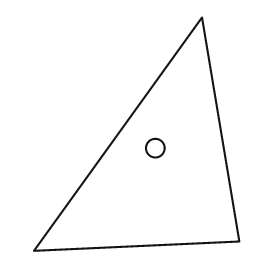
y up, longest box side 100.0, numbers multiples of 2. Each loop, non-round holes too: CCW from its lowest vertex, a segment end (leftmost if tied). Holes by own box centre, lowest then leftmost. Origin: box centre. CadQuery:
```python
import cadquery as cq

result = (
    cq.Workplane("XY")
    .moveTo(-44.0, -50.0)
    .lineTo(44.0, -46.0)
    .lineTo(28.0, 50.0)
    .close()
    .moveTo(8.0, -6.0)
    .circle(4.0)
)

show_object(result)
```